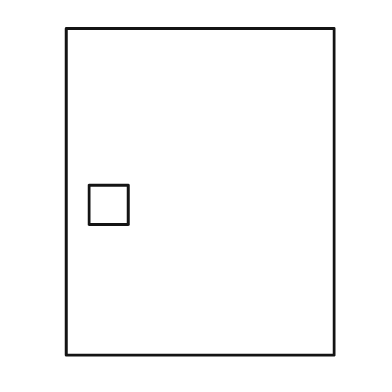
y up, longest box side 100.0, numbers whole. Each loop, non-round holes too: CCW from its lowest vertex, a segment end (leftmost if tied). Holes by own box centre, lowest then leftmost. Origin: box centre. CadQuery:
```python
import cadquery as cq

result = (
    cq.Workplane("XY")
    .moveTo(-41.0, -50.0)
    .lineTo(41.0, -50.0)
    .lineTo(41.0, 50.0)
    .lineTo(-41.0, 50.0)
    .close()
    .moveTo(-34.0, -10.0)
    .lineTo(-22.0, -10.0)
    .lineTo(-22.0, 2.0)
    .lineTo(-34.0, 2.0)
    .close()
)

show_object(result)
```